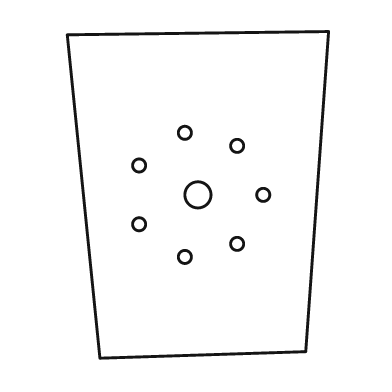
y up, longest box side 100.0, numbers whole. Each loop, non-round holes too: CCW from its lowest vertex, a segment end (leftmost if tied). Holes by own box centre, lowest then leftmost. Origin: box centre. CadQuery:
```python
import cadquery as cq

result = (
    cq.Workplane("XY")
    .moveTo(-30.0, -50.0)
    .lineTo(33.0, -48.0)
    .lineTo(40.0, 50.0)
    .lineTo(-40.0, 49.0)
    .close()
    .moveTo(-4.0, -19.0)
    .circle(2.0)
    .moveTo(12.0, -15.0)
    .circle(2.0)
    .moveTo(-18.0, -9.0)
    .circle(2.0)
    .moveTo(0.0, 0.0)
    .circle(4.0)
    .moveTo(20.0, 0.0)
    .circle(2.0)
    .moveTo(-18.0, 9.0)
    .circle(2.0)
    .moveTo(12.0, 15.0)
    .circle(2.0)
    .moveTo(-4.0, 19.0)
    .circle(2.0)
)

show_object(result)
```